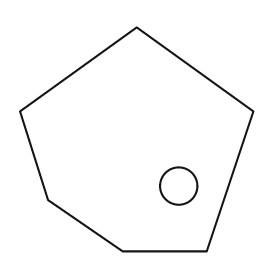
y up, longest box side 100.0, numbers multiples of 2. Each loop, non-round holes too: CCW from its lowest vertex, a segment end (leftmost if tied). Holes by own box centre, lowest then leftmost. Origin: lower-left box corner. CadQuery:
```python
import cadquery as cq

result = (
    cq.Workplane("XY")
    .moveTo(44.0, 0.0)
    .lineTo(80.0, 0.0)
    .lineTo(100.0, 60.0)
    .lineTo(50.0, 96.0)
    .lineTo(0.0, 60.0)
    .lineTo(12.0, 22.0)
    .close()
    .moveTo(68.0, 28.0)
    .circle(8.0)
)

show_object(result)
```